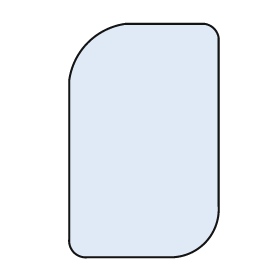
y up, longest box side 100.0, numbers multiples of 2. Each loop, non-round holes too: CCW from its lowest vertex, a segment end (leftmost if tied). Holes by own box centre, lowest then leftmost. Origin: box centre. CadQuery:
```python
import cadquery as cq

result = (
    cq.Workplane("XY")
    .moveTo(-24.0, -50.0)
    .lineTo(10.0, -50.0)
    .threePointArc((26.0, -44.0), (32.0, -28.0))
    .lineTo(32.0, 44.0)
    .threePointArc((30.0, 48.0), (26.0, 50.0))
    .lineTo(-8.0, 50.0)
    .threePointArc((-24.0, 42.0), (-32.0, 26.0))
    .lineTo(-32.0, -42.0)
    .threePointArc((-30.0, -48.0), (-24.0, -50.0))
    .close()
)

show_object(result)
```